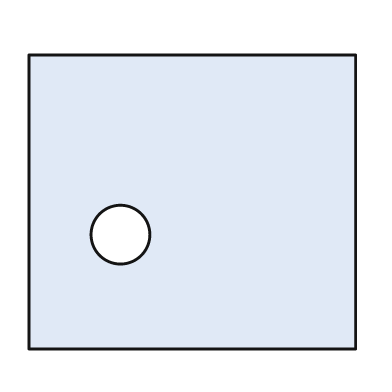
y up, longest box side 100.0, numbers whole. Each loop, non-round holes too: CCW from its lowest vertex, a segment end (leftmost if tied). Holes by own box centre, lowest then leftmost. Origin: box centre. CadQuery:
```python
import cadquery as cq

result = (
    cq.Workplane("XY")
    .moveTo(-50.0, -45.0)
    .lineTo(50.0, -45.0)
    .lineTo(50.0, 45.0)
    .lineTo(-50.0, 45.0)
    .close()
    .moveTo(-22.0, -10.0)
    .circle(9.0)
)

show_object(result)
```